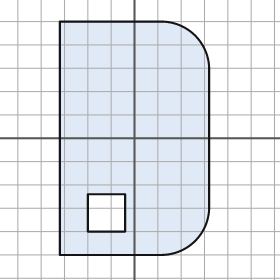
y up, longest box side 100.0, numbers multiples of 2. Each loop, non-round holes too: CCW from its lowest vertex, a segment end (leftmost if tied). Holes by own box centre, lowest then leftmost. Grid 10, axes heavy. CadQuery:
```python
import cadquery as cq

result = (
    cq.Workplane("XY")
    .moveTo(-32.0, -50.0)
    .lineTo(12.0, -50.0)
    .threePointArc((26.0, -44.0), (32.0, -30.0))
    .lineTo(32.0, 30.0)
    .threePointArc((26.0, 44.0), (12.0, 50.0))
    .lineTo(-32.0, 50.0)
    .close()
    .moveTo(-20.0, -40.0)
    .lineTo(-4.0, -40.0)
    .lineTo(-4.0, -24.0)
    .lineTo(-20.0, -24.0)
    .close()
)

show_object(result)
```